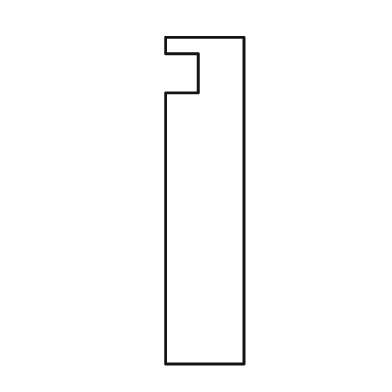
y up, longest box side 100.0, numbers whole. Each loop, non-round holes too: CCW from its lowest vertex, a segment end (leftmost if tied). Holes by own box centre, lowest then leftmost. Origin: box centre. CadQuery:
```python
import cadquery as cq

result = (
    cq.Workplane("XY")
    .moveTo(-12.0, -50.0)
    .lineTo(12.0, -50.0)
    .lineTo(12.0, 50.0)
    .lineTo(-12.0, 50.0)
    .lineTo(-12.0, 45.0)
    .lineTo(-2.0, 45.0)
    .lineTo(-2.0, 33.0)
    .lineTo(-12.0, 33.0)
    .close()
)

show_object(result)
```